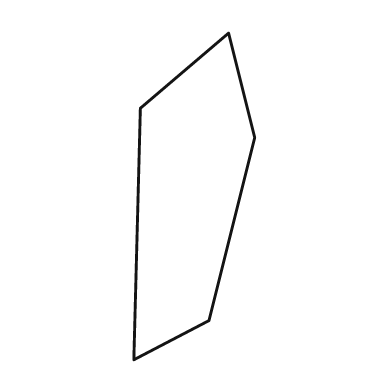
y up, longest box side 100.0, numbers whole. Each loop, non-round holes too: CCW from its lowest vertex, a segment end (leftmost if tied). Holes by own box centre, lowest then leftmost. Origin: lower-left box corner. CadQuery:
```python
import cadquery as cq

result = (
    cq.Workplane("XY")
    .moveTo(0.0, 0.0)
    .lineTo(23.0, 12.0)
    .lineTo(37.0, 68.0)
    .lineTo(29.0, 100.0)
    .lineTo(2.0, 77.0)
    .close()
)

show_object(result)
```